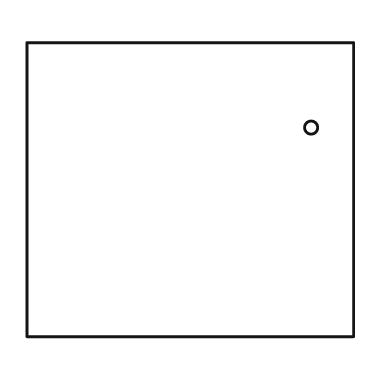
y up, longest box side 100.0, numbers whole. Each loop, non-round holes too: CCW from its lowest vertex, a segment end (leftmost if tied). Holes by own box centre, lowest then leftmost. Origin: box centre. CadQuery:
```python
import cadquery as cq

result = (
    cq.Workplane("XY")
    .moveTo(-50.0, -45.0)
    .lineTo(50.0, -45.0)
    .lineTo(50.0, 45.0)
    .lineTo(-50.0, 45.0)
    .close()
    .moveTo(37.0, 19.0)
    .circle(2.0)
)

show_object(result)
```